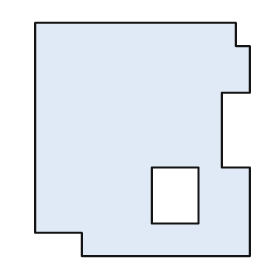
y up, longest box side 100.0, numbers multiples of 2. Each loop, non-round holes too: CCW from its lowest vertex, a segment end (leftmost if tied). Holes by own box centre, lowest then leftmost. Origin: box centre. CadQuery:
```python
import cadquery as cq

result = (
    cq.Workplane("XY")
    .moveTo(-26.0, -50.0)
    .lineTo(46.0, -50.0)
    .lineTo(46.0, -12.0)
    .lineTo(34.0, -12.0)
    .lineTo(34.0, 20.0)
    .lineTo(46.0, 20.0)
    .lineTo(46.0, 40.0)
    .lineTo(40.0, 40.0)
    .lineTo(40.0, 50.0)
    .lineTo(-46.0, 50.0)
    .lineTo(-46.0, -40.0)
    .lineTo(-26.0, -40.0)
    .close()
    .moveTo(4.0, -36.0)
    .lineTo(24.0, -36.0)
    .lineTo(24.0, -12.0)
    .lineTo(4.0, -12.0)
    .close()
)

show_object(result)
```